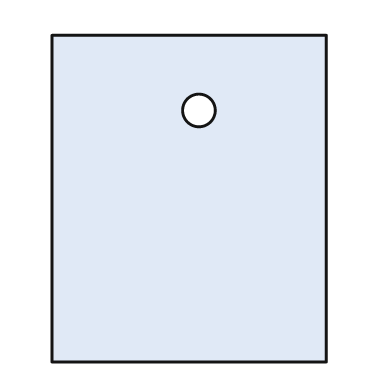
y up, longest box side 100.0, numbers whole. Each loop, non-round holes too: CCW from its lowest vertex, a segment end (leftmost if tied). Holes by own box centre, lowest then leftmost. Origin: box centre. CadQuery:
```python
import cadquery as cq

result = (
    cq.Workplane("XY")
    .moveTo(-42.0, -50.0)
    .lineTo(42.0, -50.0)
    .lineTo(42.0, 50.0)
    .lineTo(-42.0, 50.0)
    .close()
    .moveTo(3.0, 27.0)
    .circle(5.0)
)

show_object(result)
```